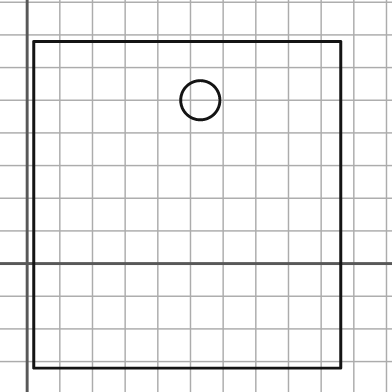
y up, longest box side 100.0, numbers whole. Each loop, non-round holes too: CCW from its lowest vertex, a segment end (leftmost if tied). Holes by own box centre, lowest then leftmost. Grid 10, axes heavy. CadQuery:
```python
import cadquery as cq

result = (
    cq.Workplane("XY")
    .moveTo(2.0, -32.0)
    .lineTo(96.0, -32.0)
    .lineTo(96.0, 68.0)
    .lineTo(2.0, 68.0)
    .close()
    .moveTo(53.0, 50.0)
    .circle(6.0)
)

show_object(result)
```